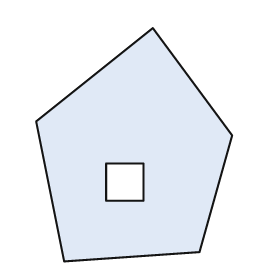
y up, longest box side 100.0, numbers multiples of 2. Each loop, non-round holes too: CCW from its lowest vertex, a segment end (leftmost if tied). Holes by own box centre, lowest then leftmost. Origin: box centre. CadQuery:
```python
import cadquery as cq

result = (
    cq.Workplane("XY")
    .moveTo(-30.0, -50.0)
    .lineTo(28.0, -46.0)
    .lineTo(42.0, 4.0)
    .lineTo(8.0, 50.0)
    .lineTo(-42.0, 10.0)
    .close()
    .moveTo(-12.0, -24.0)
    .lineTo(4.0, -24.0)
    .lineTo(4.0, -8.0)
    .lineTo(-12.0, -8.0)
    .close()
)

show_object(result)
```